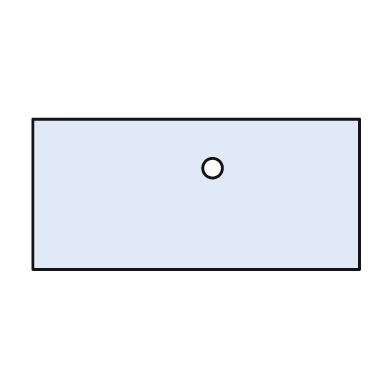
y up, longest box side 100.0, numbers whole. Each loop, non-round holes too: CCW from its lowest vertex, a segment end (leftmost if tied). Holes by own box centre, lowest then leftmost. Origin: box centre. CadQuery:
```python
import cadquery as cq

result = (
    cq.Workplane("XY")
    .moveTo(-50.0, -23.0)
    .lineTo(50.0, -23.0)
    .lineTo(50.0, 23.0)
    .lineTo(-50.0, 23.0)
    .close()
    .moveTo(5.0, 8.0)
    .circle(3.0)
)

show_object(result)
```